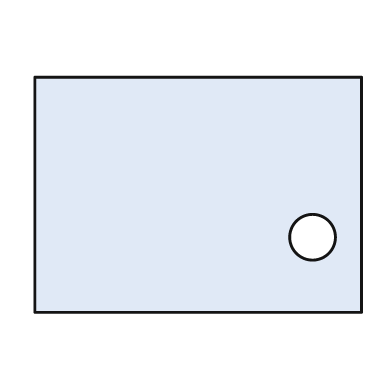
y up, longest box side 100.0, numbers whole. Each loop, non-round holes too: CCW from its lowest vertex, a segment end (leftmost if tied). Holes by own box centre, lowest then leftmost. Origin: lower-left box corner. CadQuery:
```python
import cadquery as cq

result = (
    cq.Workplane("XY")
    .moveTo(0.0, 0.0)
    .lineTo(100.0, 0.0)
    .lineTo(100.0, 72.0)
    .lineTo(0.0, 72.0)
    .close()
    .moveTo(85.0, 23.0)
    .circle(7.0)
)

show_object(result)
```